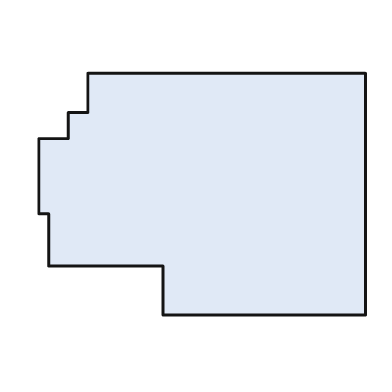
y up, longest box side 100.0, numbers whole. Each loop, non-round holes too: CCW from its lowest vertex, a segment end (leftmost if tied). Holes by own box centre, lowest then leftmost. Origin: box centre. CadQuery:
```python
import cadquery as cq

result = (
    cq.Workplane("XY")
    .moveTo(-12.0, -37.0)
    .lineTo(50.0, -37.0)
    .lineTo(50.0, 37.0)
    .lineTo(-35.0, 37.0)
    .lineTo(-35.0, 25.0)
    .lineTo(-41.0, 25.0)
    .lineTo(-41.0, 17.0)
    .lineTo(-50.0, 17.0)
    .lineTo(-50.0, -6.0)
    .lineTo(-47.0, -6.0)
    .lineTo(-47.0, -22.0)
    .lineTo(-12.0, -22.0)
    .close()
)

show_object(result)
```